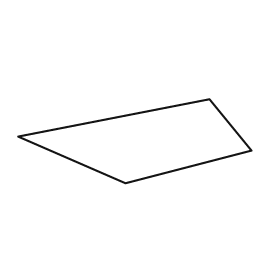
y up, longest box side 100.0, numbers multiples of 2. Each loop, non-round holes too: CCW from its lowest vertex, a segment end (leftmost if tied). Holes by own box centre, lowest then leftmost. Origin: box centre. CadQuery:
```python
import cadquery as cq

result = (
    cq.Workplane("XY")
    .moveTo(-4.0, -18.0)
    .lineTo(50.0, -4.0)
    .lineTo(32.0, 18.0)
    .lineTo(-50.0, 2.0)
    .close()
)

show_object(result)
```